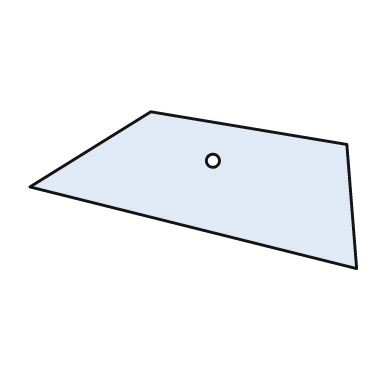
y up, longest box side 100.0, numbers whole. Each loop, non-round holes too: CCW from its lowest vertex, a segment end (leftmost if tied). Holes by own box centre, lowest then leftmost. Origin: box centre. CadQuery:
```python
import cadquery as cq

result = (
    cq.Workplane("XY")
    .moveTo(50.0, -24.0)
    .lineTo(47.0, 14.0)
    .lineTo(-13.0, 24.0)
    .lineTo(-50.0, 1.0)
    .close()
    .moveTo(6.0, 9.0)
    .circle(2.0)
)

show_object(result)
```